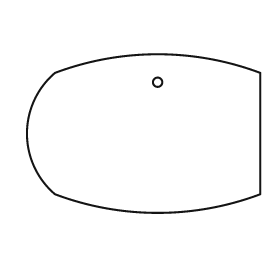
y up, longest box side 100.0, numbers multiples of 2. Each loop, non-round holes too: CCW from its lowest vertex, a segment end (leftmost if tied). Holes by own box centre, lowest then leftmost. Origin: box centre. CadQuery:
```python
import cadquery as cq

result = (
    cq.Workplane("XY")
    .moveTo(-38.0, -26.0)
    .threePointArc((6.0, -34.0), (50.0, -26.0))
    .lineTo(50.0, 26.0)
    .threePointArc((6.0, 34.0), (-38.0, 26.0))
    .threePointArc((-50.0, 0.0), (-38.0, -26.0))
    .close()
    .moveTo(6.0, 22.0)
    .circle(2.0)
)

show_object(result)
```